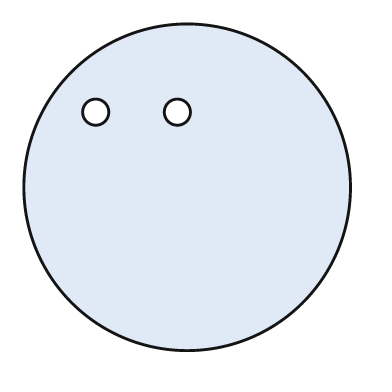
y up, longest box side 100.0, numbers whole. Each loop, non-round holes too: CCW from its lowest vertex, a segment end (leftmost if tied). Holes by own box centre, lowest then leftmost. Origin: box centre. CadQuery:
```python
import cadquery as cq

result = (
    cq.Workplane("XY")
    .moveTo(0.0, 0.0)
    .circle(50.0)
    .moveTo(-28.0, 23.0)
    .circle(4.0)
    .moveTo(-3.0, 23.0)
    .circle(4.0)
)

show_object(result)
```